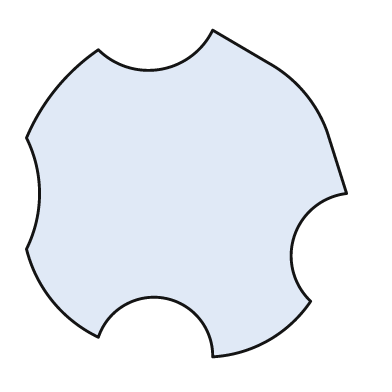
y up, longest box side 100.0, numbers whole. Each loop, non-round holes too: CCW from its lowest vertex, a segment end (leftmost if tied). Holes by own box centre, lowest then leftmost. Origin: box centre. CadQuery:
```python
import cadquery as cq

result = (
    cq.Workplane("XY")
    .moveTo(8.0, -50.0)
    .threePointArc((25.0, -45.0), (38.0, -33.0))
    .threePointArc((33.0, -13.0), (49.0, 0.0))
    .lineTo(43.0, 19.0)
    .threePointArc((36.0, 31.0), (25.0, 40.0))
    .lineTo(8.0, 50.0)
    .threePointArc((-8.0, 38.0), (-27.0, 44.0))
    .threePointArc((-40.0, 32.0), (-49.0, 17.0))
    .threePointArc((-45.0, 0.0), (-49.0, -17.0))
    .threePointArc((-41.0, -33.0), (-27.0, -44.0))
    .threePointArc((-7.0, -32.0), (8.0, -50.0))
    .close()
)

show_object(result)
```